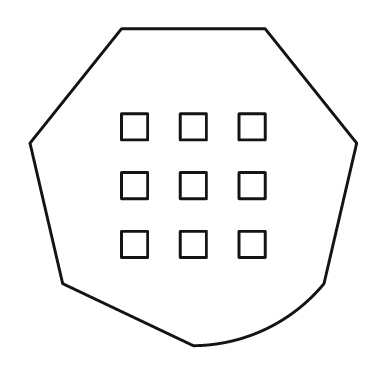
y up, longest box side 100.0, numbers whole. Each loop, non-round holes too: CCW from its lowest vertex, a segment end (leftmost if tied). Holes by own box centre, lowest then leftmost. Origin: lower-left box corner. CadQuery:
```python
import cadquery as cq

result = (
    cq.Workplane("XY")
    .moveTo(50.0, 0.0)
    .threePointArc((72.0, 5.0), (90.0, 19.0))
    .lineTo(100.0, 62.0)
    .lineTo(72.0, 97.0)
    .lineTo(28.0, 97.0)
    .lineTo(0.0, 62.0)
    .lineTo(10.0, 19.0)
    .close()
    .moveTo(28.0, 27.0)
    .lineTo(36.0, 27.0)
    .lineTo(36.0, 35.0)
    .lineTo(28.0, 35.0)
    .close()
    .moveTo(46.0, 27.0)
    .lineTo(54.0, 27.0)
    .lineTo(54.0, 35.0)
    .lineTo(46.0, 35.0)
    .close()
    .moveTo(64.0, 27.0)
    .lineTo(72.0, 27.0)
    .lineTo(72.0, 35.0)
    .lineTo(64.0, 35.0)
    .close()
    .moveTo(28.0, 45.0)
    .lineTo(36.0, 45.0)
    .lineTo(36.0, 53.0)
    .lineTo(28.0, 53.0)
    .close()
    .moveTo(46.0, 45.0)
    .lineTo(54.0, 45.0)
    .lineTo(54.0, 53.0)
    .lineTo(46.0, 53.0)
    .close()
    .moveTo(64.0, 45.0)
    .lineTo(72.0, 45.0)
    .lineTo(72.0, 53.0)
    .lineTo(64.0, 53.0)
    .close()
    .moveTo(28.0, 63.0)
    .lineTo(36.0, 63.0)
    .lineTo(36.0, 71.0)
    .lineTo(28.0, 71.0)
    .close()
    .moveTo(46.0, 63.0)
    .lineTo(54.0, 63.0)
    .lineTo(54.0, 71.0)
    .lineTo(46.0, 71.0)
    .close()
    .moveTo(64.0, 63.0)
    .lineTo(72.0, 63.0)
    .lineTo(72.0, 71.0)
    .lineTo(64.0, 71.0)
    .close()
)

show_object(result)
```